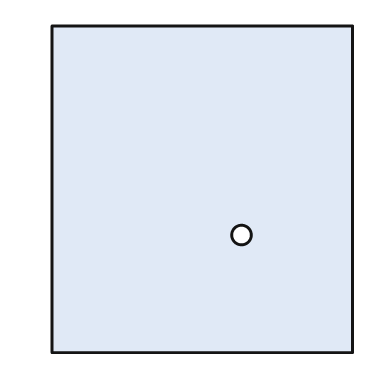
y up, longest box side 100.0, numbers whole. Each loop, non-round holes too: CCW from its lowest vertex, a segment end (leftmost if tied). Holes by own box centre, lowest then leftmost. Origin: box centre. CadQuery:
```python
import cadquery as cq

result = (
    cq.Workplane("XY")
    .moveTo(-46.0, -50.0)
    .lineTo(46.0, -50.0)
    .lineTo(46.0, 50.0)
    .lineTo(-46.0, 50.0)
    .close()
    .moveTo(12.0, -14.0)
    .circle(3.0)
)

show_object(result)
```